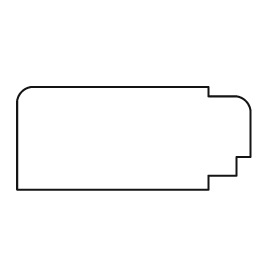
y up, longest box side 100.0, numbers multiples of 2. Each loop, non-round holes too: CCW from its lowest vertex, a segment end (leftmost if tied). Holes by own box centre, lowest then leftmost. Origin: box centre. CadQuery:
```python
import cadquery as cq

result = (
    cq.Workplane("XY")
    .moveTo(-50.0, -22.0)
    .lineTo(32.0, -22.0)
    .lineTo(32.0, -16.0)
    .lineTo(44.0, -16.0)
    .lineTo(44.0, -8.0)
    .lineTo(50.0, -8.0)
    .lineTo(50.0, 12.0)
    .threePointArc((48.0, 16.0), (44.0, 18.0))
    .lineTo(32.0, 18.0)
    .lineTo(32.0, 22.0)
    .lineTo(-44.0, 22.0)
    .threePointArc((-48.0, 20.0), (-50.0, 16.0))
    .close()
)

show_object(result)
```